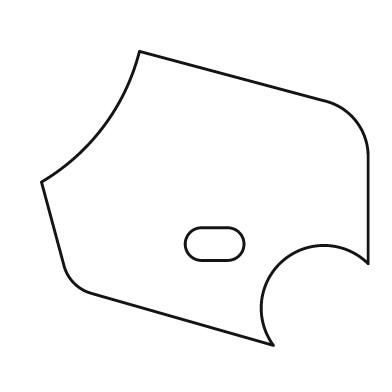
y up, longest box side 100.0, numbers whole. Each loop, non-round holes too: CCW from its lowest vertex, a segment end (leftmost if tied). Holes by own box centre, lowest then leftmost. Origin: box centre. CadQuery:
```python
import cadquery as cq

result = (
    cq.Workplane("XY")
    .moveTo(21.0, -45.0)
    .threePointArc((24.0, -19.0), (50.0, -20.0))
    .lineTo(50.0, 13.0)
    .threePointArc((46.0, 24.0), (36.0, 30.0))
    .lineTo(-20.0, 45.0)
    .threePointArc((-31.0, 22.0), (-50.0, 5.0))
    .lineTo(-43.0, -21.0)
    .threePointArc((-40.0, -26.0), (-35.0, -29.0))
    .close()
    .moveTo(-1.0, -19.0)
    .lineTo(7.0, -19.0)
    .threePointArc((12.0, -14.0), (7.0, -9.0))
    .lineTo(-1.0, -9.0)
    .threePointArc((-6.0, -14.0), (-1.0, -19.0))
    .close()
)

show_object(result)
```